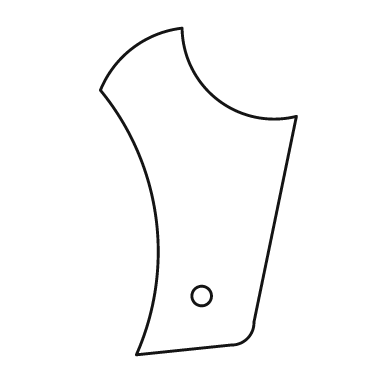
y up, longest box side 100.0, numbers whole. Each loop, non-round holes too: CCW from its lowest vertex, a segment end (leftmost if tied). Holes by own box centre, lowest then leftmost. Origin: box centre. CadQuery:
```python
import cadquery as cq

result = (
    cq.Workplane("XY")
    .moveTo(-19.0, -50.0)
    .lineTo(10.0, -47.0)
    .threePointArc((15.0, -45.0), (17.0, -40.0))
    .lineTo(30.0, 23.0)
    .threePointArc((6.0, 28.0), (-5.0, 50.0))
    .threePointArc((-20.0, 44.0), (-30.0, 31.0))
    .threePointArc((-13.0, -8.0), (-19.0, -50.0))
    .close()
    .moveTo(1.0, -32.0)
    .circle(3.0)
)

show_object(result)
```